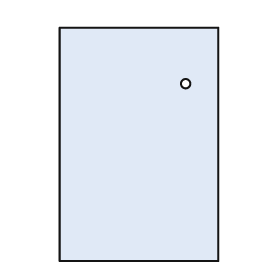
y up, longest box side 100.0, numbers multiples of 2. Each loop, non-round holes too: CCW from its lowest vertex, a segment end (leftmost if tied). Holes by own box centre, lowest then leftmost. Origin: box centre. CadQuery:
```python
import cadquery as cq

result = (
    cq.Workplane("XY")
    .moveTo(-34.0, -50.0)
    .lineTo(34.0, -50.0)
    .lineTo(34.0, 50.0)
    .lineTo(-34.0, 50.0)
    .close()
    .moveTo(20.0, 26.0)
    .circle(2.0)
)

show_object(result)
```